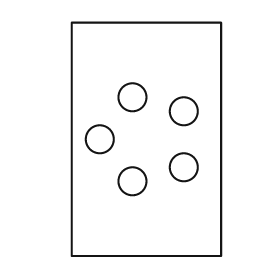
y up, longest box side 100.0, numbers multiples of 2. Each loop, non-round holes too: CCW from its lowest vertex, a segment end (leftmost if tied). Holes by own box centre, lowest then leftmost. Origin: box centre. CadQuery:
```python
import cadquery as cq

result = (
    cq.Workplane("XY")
    .moveTo(-32.0, -50.0)
    .lineTo(32.0, -50.0)
    .lineTo(32.0, 50.0)
    .lineTo(-32.0, 50.0)
    .close()
    .moveTo(-6.0, -18.0)
    .circle(6.0)
    .moveTo(16.0, -12.0)
    .circle(6.0)
    .moveTo(-20.0, 0.0)
    .circle(6.0)
    .moveTo(16.0, 12.0)
    .circle(6.0)
    .moveTo(-6.0, 18.0)
    .circle(6.0)
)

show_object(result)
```